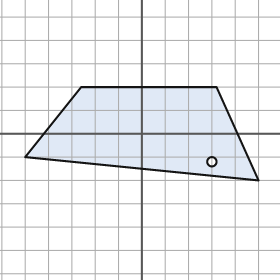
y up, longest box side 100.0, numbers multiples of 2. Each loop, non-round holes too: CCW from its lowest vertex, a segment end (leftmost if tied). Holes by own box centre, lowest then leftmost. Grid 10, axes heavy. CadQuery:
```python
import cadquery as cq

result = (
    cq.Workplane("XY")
    .moveTo(50.0, -20.0)
    .lineTo(32.0, 20.0)
    .lineTo(-26.0, 20.0)
    .lineTo(-50.0, -10.0)
    .close()
    .moveTo(30.0, -12.0)
    .circle(2.0)
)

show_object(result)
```